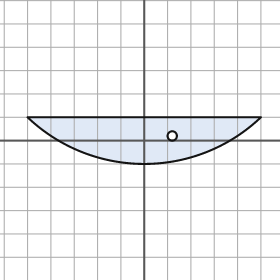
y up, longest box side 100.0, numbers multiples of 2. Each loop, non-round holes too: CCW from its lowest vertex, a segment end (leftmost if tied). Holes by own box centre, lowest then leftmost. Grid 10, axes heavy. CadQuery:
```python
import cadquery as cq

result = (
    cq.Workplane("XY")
    .moveTo(-50.0, 10.0)
    .threePointArc((0.0, -10.0), (50.0, 10.0))
    .close()
    .moveTo(12.0, 2.0)
    .circle(2.0)
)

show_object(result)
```